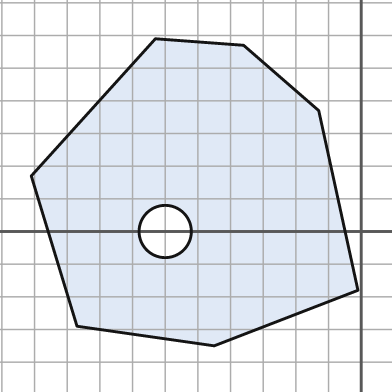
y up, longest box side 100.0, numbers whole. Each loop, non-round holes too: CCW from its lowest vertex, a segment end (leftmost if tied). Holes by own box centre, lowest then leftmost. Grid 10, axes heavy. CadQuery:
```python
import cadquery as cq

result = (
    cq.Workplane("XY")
    .moveTo(-45.0, -35.0)
    .lineTo(-1.0, -18.0)
    .lineTo(-13.0, 37.0)
    .lineTo(-36.0, 57.0)
    .lineTo(-63.0, 59.0)
    .lineTo(-101.0, 17.0)
    .lineTo(-87.0, -29.0)
    .close()
    .moveTo(-60.0, 0.0)
    .circle(8.0)
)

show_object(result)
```